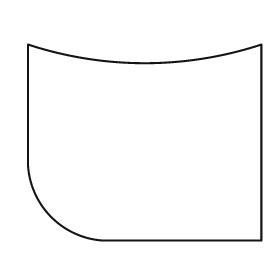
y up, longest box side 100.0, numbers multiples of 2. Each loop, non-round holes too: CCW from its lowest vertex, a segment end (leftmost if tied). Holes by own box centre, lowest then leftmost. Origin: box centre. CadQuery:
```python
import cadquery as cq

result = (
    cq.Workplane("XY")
    .moveTo(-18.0, -42.0)
    .lineTo(50.0, -42.0)
    .lineTo(50.0, 42.0)
    .threePointArc((0.0, 34.0), (-50.0, 42.0))
    .lineTo(-50.0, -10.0)
    .threePointArc((-40.0, -32.0), (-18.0, -42.0))
    .close()
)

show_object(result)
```